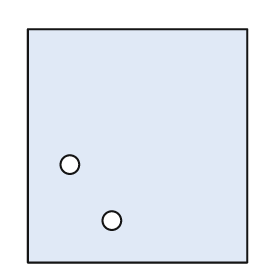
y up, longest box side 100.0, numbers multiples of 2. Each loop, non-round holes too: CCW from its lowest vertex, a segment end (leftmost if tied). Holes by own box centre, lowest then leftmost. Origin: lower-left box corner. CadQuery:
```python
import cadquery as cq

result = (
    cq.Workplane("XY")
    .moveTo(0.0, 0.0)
    .lineTo(94.0, 0.0)
    .lineTo(94.0, 100.0)
    .lineTo(0.0, 100.0)
    .close()
    .moveTo(36.0, 18.0)
    .circle(4.0)
    .moveTo(18.0, 42.0)
    .circle(4.0)
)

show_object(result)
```